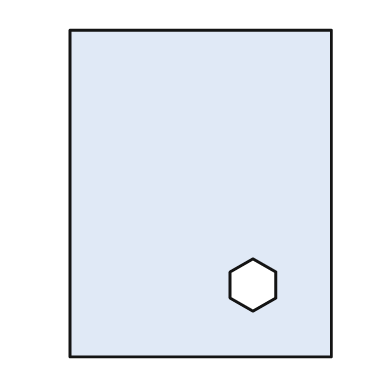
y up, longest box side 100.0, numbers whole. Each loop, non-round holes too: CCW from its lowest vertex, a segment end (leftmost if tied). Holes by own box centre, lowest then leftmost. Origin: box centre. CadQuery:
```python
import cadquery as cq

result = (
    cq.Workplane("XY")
    .moveTo(-40.0, -50.0)
    .lineTo(40.0, -50.0)
    .lineTo(40.0, 50.0)
    .lineTo(-40.0, 50.0)
    .close()
    .moveTo(16.0, -36.0)
    .lineTo(23.0, -32.0)
    .lineTo(23.0, -24.0)
    .lineTo(16.0, -20.0)
    .lineTo(9.0, -24.0)
    .lineTo(9.0, -32.0)
    .close()
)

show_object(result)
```